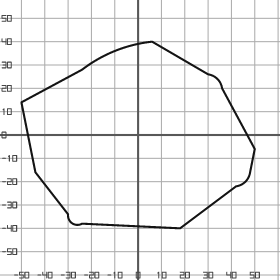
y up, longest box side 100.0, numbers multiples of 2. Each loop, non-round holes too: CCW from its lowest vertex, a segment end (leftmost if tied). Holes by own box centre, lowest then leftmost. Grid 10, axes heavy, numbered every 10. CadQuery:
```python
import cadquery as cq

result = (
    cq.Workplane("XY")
    .moveTo(18.0, -40.0)
    .lineTo(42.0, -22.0)
    .threePointArc((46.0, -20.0), (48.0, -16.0))
    .lineTo(50.0, -6.0)
    .lineTo(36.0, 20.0)
    .threePointArc((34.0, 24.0), (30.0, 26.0))
    .lineTo(6.0, 40.0)
    .threePointArc((-10.0, 36.0), (-24.0, 28.0))
    .lineTo(-50.0, 14.0)
    .lineTo(-44.0, -16.0)
    .lineTo(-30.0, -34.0)
    .threePointArc((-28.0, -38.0), (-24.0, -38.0))
    .close()
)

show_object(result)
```